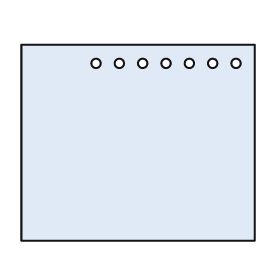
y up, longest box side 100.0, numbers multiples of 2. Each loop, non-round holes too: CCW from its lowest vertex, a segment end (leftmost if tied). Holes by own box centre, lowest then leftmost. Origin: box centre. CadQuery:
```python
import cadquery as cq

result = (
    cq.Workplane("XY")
    .moveTo(-50.0, -42.0)
    .lineTo(50.0, -42.0)
    .lineTo(50.0, 42.0)
    .lineTo(-50.0, 42.0)
    .close()
    .moveTo(-18.0, 34.0)
    .circle(2.0)
    .moveTo(-8.0, 34.0)
    .circle(2.0)
    .moveTo(2.0, 34.0)
    .circle(2.0)
    .moveTo(12.0, 34.0)
    .circle(2.0)
    .moveTo(22.0, 34.0)
    .circle(2.0)
    .moveTo(32.0, 34.0)
    .circle(2.0)
    .moveTo(42.0, 34.0)
    .circle(2.0)
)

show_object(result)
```